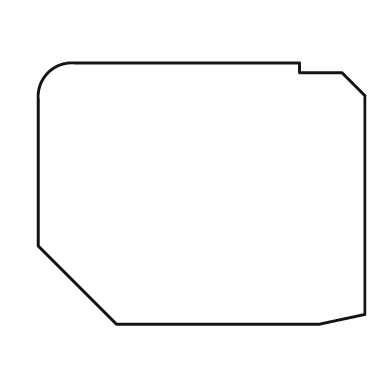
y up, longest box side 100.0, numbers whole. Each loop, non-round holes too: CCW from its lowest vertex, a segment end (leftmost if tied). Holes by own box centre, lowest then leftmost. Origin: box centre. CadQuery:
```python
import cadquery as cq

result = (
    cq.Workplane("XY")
    .moveTo(-26.0, -40.0)
    .lineTo(36.0, -40.0)
    .lineTo(50.0, -37.0)
    .lineTo(50.0, 30.0)
    .lineTo(43.0, 37.0)
    .lineTo(30.0, 37.0)
    .lineTo(30.0, 40.0)
    .lineTo(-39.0, 40.0)
    .threePointArc((-47.0, 37.0), (-50.0, 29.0))
    .lineTo(-50.0, -16.0)
    .close()
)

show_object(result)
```